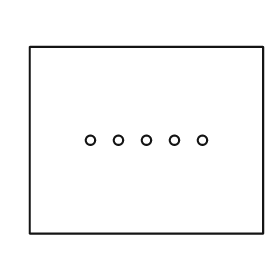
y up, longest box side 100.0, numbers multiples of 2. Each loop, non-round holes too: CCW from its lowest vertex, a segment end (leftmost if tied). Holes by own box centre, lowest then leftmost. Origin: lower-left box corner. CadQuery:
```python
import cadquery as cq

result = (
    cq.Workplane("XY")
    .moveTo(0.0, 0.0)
    .lineTo(100.0, 0.0)
    .lineTo(100.0, 80.0)
    .lineTo(0.0, 80.0)
    .close()
    .moveTo(26.0, 40.0)
    .circle(2.0)
    .moveTo(38.0, 40.0)
    .circle(2.0)
    .moveTo(50.0, 40.0)
    .circle(2.0)
    .moveTo(62.0, 40.0)
    .circle(2.0)
    .moveTo(74.0, 40.0)
    .circle(2.0)
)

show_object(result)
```